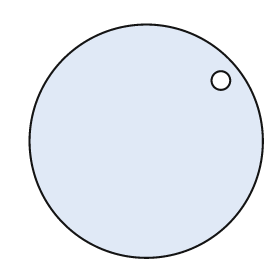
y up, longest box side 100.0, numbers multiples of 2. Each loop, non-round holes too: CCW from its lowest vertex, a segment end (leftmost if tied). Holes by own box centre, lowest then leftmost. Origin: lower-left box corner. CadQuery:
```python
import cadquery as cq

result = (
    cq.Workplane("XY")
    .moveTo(50.0, 50.0)
    .circle(50.0)
    .moveTo(82.0, 76.0)
    .circle(4.0)
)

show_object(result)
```